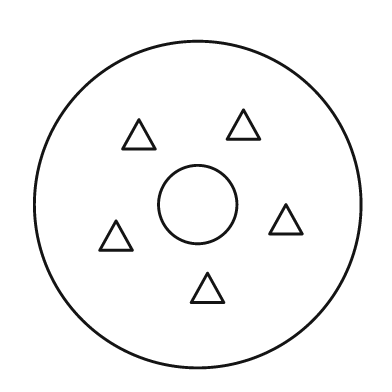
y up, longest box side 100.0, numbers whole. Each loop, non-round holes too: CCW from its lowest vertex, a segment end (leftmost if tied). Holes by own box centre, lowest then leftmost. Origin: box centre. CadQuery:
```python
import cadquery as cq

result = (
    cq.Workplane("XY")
    .moveTo(0.0, 0.0)
    .circle(50.0)
    .moveTo(-2.0, -30.0)
    .lineTo(8.0, -30.0)
    .lineTo(3.0, -21.0)
    .close()
    .moveTo(-30.0, -14.0)
    .lineTo(-20.0, -14.0)
    .lineTo(-25.0, -5.0)
    .close()
    .moveTo(22.0, -9.0)
    .lineTo(32.0, -9.0)
    .lineTo(27.0, 0.0)
    .close()
    .moveTo(0.0, 0.0)
    .circle(12.0)
    .moveTo(-23.0, 17.0)
    .lineTo(-13.0, 17.0)
    .lineTo(-18.0, 26.0)
    .close()
    .moveTo(9.0, 20.0)
    .lineTo(19.0, 20.0)
    .lineTo(14.0, 29.0)
    .close()
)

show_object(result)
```